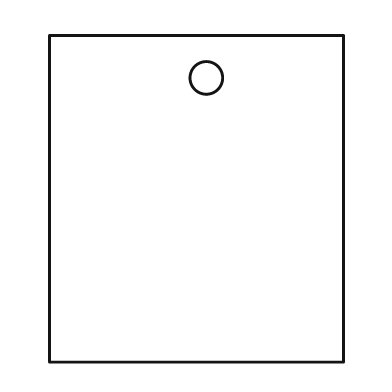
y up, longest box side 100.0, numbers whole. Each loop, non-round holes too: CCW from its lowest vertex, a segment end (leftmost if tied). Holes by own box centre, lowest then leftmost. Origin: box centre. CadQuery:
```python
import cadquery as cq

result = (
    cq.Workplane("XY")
    .moveTo(-45.0, -50.0)
    .lineTo(45.0, -50.0)
    .lineTo(45.0, 50.0)
    .lineTo(-45.0, 50.0)
    .close()
    .moveTo(3.0, 37.0)
    .circle(5.0)
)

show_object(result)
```